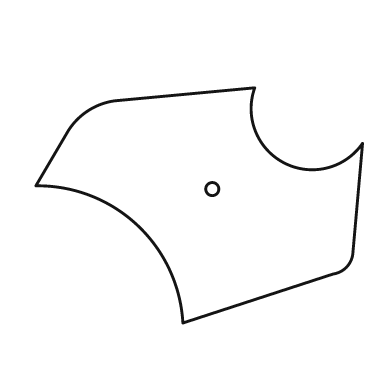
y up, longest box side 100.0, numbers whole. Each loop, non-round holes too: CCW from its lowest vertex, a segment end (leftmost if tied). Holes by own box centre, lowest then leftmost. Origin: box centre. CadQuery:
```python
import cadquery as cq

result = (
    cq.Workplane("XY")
    .moveTo(-5.0, -36.0)
    .lineTo(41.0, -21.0)
    .threePointArc((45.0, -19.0), (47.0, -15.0))
    .lineTo(50.0, 19.0)
    .threePointArc((26.0, 13.0), (17.0, 36.0))
    .lineTo(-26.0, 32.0)
    .threePointArc((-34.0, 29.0), (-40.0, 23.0))
    .lineTo(-50.0, 6.0)
    .threePointArc((-19.0, -6.0), (-5.0, -36.0))
    .close()
    .moveTo(4.0, 5.0)
    .circle(2.0)
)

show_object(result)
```